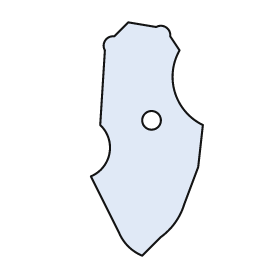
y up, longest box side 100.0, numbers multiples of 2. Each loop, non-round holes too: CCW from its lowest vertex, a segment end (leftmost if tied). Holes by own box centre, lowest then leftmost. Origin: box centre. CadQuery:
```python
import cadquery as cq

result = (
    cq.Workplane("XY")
    .moveTo(-2.0, -50.0)
    .lineTo(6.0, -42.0)
    .threePointArc((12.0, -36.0), (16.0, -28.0))
    .lineTo(22.0, -12.0)
    .lineTo(24.0, 6.0)
    .threePointArc((12.0, 20.0), (14.0, 38.0))
    .lineTo(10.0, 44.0)
    .threePointArc((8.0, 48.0), (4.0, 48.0))
    .lineTo(-8.0, 50.0)
    .lineTo(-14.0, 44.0)
    .threePointArc((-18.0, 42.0), (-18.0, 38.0))
    .lineTo(-20.0, 6.0)
    .threePointArc((-16.0, -6.0), (-24.0, -16.0))
    .lineTo(-12.0, -40.0)
    .threePointArc((-8.0, -46.0), (-2.0, -50.0))
    .close()
    .moveTo(2.0, 8.0)
    .circle(4.0)
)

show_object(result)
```